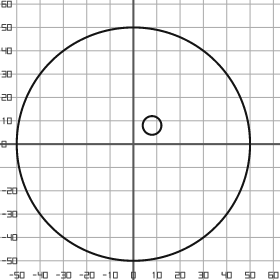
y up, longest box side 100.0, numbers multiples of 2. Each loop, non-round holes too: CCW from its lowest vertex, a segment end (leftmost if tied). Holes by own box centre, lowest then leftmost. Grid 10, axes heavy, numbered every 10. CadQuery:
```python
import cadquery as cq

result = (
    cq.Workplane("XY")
    .moveTo(0.0, 0.0)
    .circle(50.0)
    .moveTo(8.0, 8.0)
    .circle(4.0)
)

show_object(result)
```